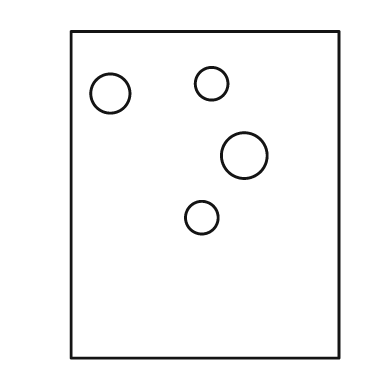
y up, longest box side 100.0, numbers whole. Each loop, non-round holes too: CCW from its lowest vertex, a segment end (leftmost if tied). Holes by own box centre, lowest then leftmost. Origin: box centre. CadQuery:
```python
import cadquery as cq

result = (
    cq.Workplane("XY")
    .moveTo(-41.0, -50.0)
    .lineTo(41.0, -50.0)
    .lineTo(41.0, 50.0)
    .lineTo(-41.0, 50.0)
    .close()
    .moveTo(-1.0, -7.0)
    .circle(5.0)
    .moveTo(12.0, 12.0)
    .circle(7.0)
    .moveTo(-29.0, 31.0)
    .circle(6.0)
    .moveTo(2.0, 34.0)
    .circle(5.0)
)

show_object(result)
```